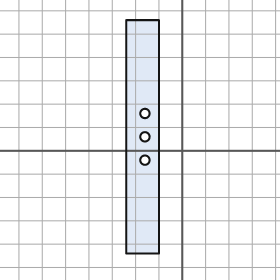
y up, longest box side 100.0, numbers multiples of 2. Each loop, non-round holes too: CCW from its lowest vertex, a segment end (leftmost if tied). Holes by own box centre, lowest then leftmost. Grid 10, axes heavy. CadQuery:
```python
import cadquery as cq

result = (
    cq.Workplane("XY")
    .moveTo(-24.0, -44.0)
    .lineTo(-10.0, -44.0)
    .lineTo(-10.0, 56.0)
    .lineTo(-24.0, 56.0)
    .close()
    .moveTo(-16.0, -4.0)
    .circle(2.0)
    .moveTo(-16.0, 6.0)
    .circle(2.0)
    .moveTo(-16.0, 16.0)
    .circle(2.0)
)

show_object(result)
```